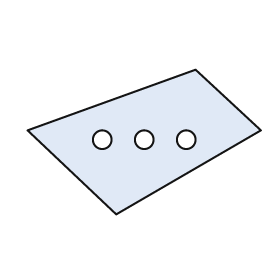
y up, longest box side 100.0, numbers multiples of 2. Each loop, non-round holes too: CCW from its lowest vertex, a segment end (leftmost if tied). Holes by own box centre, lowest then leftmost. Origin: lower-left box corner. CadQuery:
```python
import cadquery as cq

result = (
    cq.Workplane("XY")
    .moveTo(38.0, 0.0)
    .lineTo(100.0, 36.0)
    .lineTo(72.0, 62.0)
    .lineTo(0.0, 36.0)
    .close()
    .moveTo(32.0, 32.0)
    .circle(4.0)
    .moveTo(50.0, 32.0)
    .circle(4.0)
    .moveTo(68.0, 32.0)
    .circle(4.0)
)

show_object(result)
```